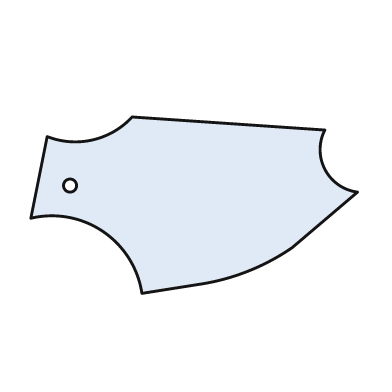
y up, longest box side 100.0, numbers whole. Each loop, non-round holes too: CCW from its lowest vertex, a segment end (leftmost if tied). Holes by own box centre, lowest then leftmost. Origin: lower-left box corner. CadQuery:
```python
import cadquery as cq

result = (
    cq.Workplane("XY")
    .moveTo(34.0, 0.0)
    .lineTo(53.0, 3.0)
    .threePointArc((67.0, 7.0), (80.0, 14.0))
    .lineTo(100.0, 31.0)
    .threePointArc((90.0, 38.0), (90.0, 50.0))
    .lineTo(31.0, 54.0)
    .threePointArc((19.0, 47.0), (5.0, 48.0))
    .lineTo(0.0, 23.0)
    .threePointArc((22.0, 19.0), (34.0, 0.0))
    .close()
    .moveTo(12.0, 33.0)
    .circle(2.0)
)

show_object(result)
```